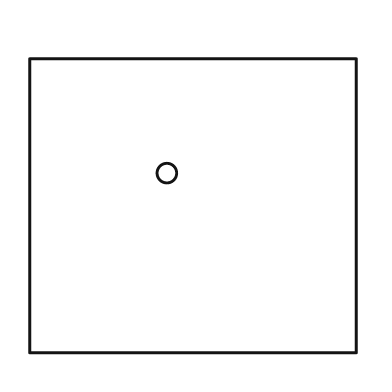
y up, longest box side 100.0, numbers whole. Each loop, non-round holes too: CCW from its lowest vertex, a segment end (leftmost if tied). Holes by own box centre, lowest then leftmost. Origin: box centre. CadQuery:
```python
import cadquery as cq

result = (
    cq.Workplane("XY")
    .moveTo(-50.0, -45.0)
    .lineTo(50.0, -45.0)
    .lineTo(50.0, 45.0)
    .lineTo(-50.0, 45.0)
    .close()
    .moveTo(-8.0, 10.0)
    .circle(3.0)
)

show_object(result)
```